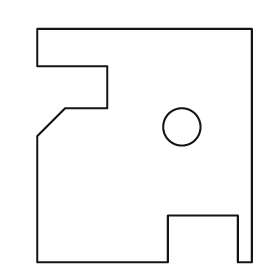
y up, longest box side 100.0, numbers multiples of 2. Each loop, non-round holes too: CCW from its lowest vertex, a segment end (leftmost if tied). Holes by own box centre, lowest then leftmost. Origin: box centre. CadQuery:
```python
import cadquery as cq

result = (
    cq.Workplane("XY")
    .moveTo(-46.0, -50.0)
    .lineTo(10.0, -50.0)
    .lineTo(10.0, -30.0)
    .lineTo(40.0, -30.0)
    .lineTo(40.0, -50.0)
    .lineTo(46.0, -50.0)
    .lineTo(46.0, 50.0)
    .lineTo(-46.0, 50.0)
    .lineTo(-46.0, 34.0)
    .lineTo(-16.0, 34.0)
    .lineTo(-16.0, 16.0)
    .lineTo(-34.0, 16.0)
    .lineTo(-46.0, 4.0)
    .close()
    .moveTo(16.0, 8.0)
    .circle(8.0)
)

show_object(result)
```